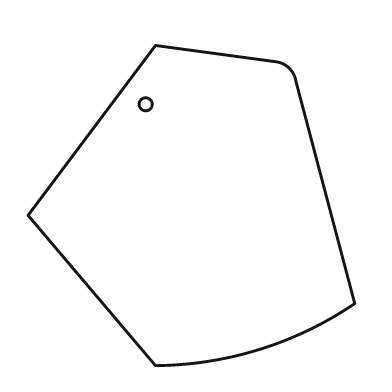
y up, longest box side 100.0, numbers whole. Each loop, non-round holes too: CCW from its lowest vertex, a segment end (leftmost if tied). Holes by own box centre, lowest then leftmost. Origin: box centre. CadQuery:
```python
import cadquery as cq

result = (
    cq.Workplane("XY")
    .moveTo(-11.0, -49.0)
    .threePointArc((21.0, -44.0), (50.0, -30.0))
    .lineTo(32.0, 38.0)
    .threePointArc((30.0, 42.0), (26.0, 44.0))
    .lineTo(-11.0, 49.0)
    .lineTo(-50.0, -3.0)
    .close()
    .moveTo(-14.0, 31.0)
    .circle(2.0)
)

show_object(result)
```